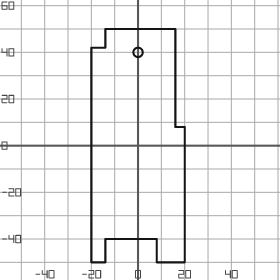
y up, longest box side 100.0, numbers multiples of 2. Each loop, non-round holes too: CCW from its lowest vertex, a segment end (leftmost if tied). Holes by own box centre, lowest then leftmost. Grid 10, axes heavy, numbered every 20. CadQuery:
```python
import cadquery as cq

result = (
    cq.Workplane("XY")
    .moveTo(-20.0, -50.0)
    .lineTo(-14.0, -50.0)
    .lineTo(-14.0, -40.0)
    .lineTo(8.0, -40.0)
    .lineTo(8.0, -50.0)
    .lineTo(20.0, -50.0)
    .lineTo(20.0, 8.0)
    .lineTo(16.0, 8.0)
    .lineTo(16.0, 50.0)
    .lineTo(-14.0, 50.0)
    .lineTo(-14.0, 42.0)
    .lineTo(-20.0, 42.0)
    .close()
    .moveTo(0.0, 40.0)
    .circle(2.0)
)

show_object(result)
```